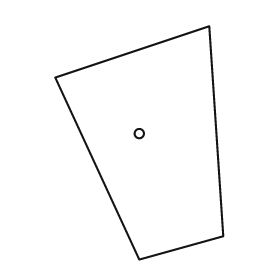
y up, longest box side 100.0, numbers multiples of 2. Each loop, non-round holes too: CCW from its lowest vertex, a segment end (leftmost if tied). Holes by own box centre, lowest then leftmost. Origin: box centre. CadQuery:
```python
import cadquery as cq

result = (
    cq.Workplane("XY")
    .moveTo(0.0, -50.0)
    .lineTo(36.0, -40.0)
    .lineTo(30.0, 50.0)
    .lineTo(-36.0, 28.0)
    .close()
    .moveTo(0.0, 4.0)
    .circle(2.0)
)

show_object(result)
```